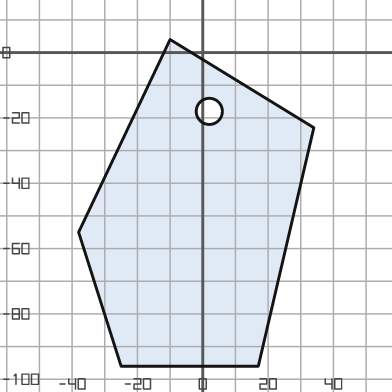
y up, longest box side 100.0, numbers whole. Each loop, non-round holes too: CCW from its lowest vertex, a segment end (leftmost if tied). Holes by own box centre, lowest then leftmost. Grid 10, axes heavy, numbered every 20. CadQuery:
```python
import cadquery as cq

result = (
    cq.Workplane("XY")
    .moveTo(-25.0, -96.0)
    .lineTo(17.0, -96.0)
    .lineTo(34.0, -23.0)
    .lineTo(-10.0, 4.0)
    .lineTo(-38.0, -55.0)
    .close()
    .moveTo(2.0, -18.0)
    .circle(4.0)
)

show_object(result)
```